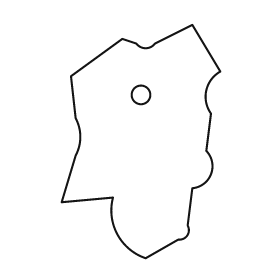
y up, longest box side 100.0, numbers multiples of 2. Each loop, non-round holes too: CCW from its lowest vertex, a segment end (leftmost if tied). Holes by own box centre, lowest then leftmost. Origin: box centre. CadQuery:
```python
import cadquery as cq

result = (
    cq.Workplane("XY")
    .moveTo(2.0, -50.0)
    .lineTo(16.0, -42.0)
    .threePointArc((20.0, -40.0), (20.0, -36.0))
    .lineTo(22.0, -20.0)
    .threePointArc((30.0, -14.0), (28.0, -4.0))
    .lineTo(30.0, 12.0)
    .threePointArc((28.0, 22.0), (34.0, 30.0))
    .lineTo(22.0, 50.0)
    .lineTo(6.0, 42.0)
    .threePointArc((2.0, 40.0), (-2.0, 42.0))
    .lineTo(-8.0, 44.0)
    .lineTo(-30.0, 28.0)
    .lineTo(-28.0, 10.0)
    .threePointArc((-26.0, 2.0), (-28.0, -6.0))
    .lineTo(-34.0, -26.0)
    .lineTo(-12.0, -24.0)
    .threePointArc((-10.0, -40.0), (2.0, -50.0))
    .close()
    .moveTo(0.0, 20.0)
    .circle(4.0)
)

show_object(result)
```